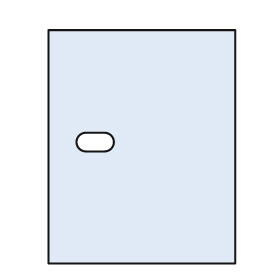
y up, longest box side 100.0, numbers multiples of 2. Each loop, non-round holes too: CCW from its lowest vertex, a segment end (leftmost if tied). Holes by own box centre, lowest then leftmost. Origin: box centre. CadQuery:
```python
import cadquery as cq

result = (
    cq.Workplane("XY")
    .moveTo(-40.0, -50.0)
    .lineTo(40.0, -50.0)
    .lineTo(40.0, 50.0)
    .lineTo(-40.0, 50.0)
    .close()
    .moveTo(-24.0, -2.0)
    .lineTo(-16.0, -2.0)
    .threePointArc((-12.0, 2.0), (-16.0, 6.0))
    .lineTo(-24.0, 6.0)
    .threePointArc((-28.0, 2.0), (-24.0, -2.0))
    .close()
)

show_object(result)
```